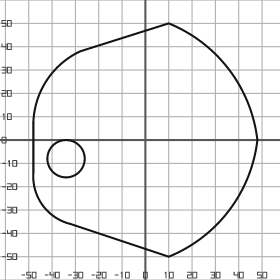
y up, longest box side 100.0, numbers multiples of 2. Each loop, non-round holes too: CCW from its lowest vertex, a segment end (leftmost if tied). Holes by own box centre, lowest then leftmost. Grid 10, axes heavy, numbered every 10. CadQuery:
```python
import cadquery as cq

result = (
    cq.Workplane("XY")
    .moveTo(10.0, -50.0)
    .threePointArc((36.0, -30.0), (48.0, 0.0))
    .threePointArc((36.0, 30.0), (10.0, 50.0))
    .lineTo(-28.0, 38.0)
    .threePointArc((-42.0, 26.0), (-48.0, 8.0))
    .lineTo(-48.0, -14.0)
    .threePointArc((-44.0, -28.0), (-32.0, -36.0))
    .close()
    .moveTo(-34.0, -8.0)
    .circle(8.0)
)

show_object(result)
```